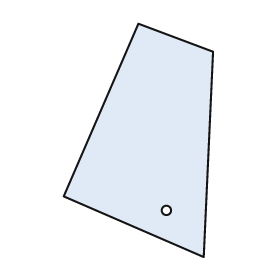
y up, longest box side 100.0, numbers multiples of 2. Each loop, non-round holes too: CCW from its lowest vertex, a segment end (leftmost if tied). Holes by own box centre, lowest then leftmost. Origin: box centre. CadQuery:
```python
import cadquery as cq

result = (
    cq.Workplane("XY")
    .moveTo(28.0, -50.0)
    .lineTo(32.0, 38.0)
    .lineTo(0.0, 50.0)
    .lineTo(-32.0, -24.0)
    .close()
    .moveTo(12.0, -30.0)
    .circle(2.0)
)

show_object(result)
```